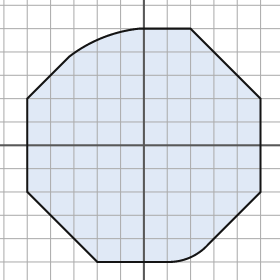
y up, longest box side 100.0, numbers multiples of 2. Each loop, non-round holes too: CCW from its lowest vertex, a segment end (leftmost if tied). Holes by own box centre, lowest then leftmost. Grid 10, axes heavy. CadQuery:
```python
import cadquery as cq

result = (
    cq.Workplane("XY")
    .moveTo(-20.0, -50.0)
    .lineTo(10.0, -50.0)
    .threePointArc((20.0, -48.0), (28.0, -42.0))
    .lineTo(50.0, -20.0)
    .lineTo(50.0, 20.0)
    .lineTo(20.0, 50.0)
    .lineTo(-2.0, 50.0)
    .threePointArc((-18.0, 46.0), (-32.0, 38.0))
    .lineTo(-50.0, 20.0)
    .lineTo(-50.0, -20.0)
    .close()
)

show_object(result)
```